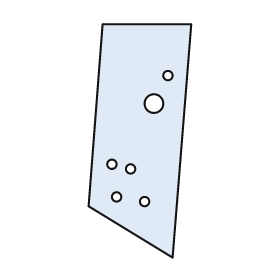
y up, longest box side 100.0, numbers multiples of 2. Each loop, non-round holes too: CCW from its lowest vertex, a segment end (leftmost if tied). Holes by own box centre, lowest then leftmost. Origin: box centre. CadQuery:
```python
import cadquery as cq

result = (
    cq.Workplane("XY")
    .moveTo(14.0, -50.0)
    .lineTo(22.0, 50.0)
    .lineTo(-16.0, 50.0)
    .lineTo(-22.0, -28.0)
    .close()
    .moveTo(2.0, -26.0)
    .circle(2.0)
    .moveTo(-10.0, -24.0)
    .circle(2.0)
    .moveTo(-4.0, -12.0)
    .circle(2.0)
    .moveTo(-12.0, -10.0)
    .circle(2.0)
    .moveTo(6.0, 16.0)
    .circle(4.0)
    .moveTo(12.0, 28.0)
    .circle(2.0)
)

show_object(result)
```